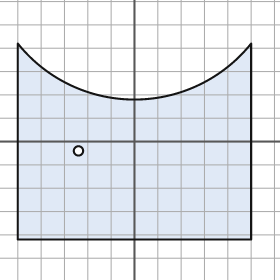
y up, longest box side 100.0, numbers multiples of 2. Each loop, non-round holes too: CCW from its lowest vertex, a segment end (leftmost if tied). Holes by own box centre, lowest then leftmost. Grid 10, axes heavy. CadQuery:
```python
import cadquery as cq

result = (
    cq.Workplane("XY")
    .moveTo(-50.0, -42.0)
    .lineTo(50.0, -42.0)
    .lineTo(50.0, 42.0)
    .threePointArc((0.0, 18.0), (-50.0, 42.0))
    .close()
    .moveTo(-24.0, -4.0)
    .circle(2.0)
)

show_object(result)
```